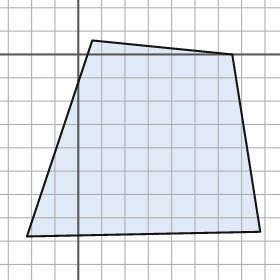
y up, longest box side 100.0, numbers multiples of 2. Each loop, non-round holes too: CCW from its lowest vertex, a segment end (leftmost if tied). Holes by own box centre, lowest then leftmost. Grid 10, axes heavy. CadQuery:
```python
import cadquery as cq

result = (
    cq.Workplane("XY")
    .moveTo(-22.0, -78.0)
    .lineTo(78.0, -76.0)
    .lineTo(66.0, 0.0)
    .lineTo(6.0, 6.0)
    .close()
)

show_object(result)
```